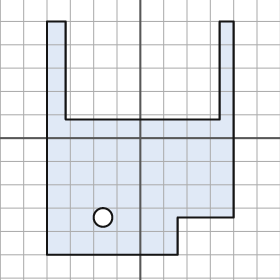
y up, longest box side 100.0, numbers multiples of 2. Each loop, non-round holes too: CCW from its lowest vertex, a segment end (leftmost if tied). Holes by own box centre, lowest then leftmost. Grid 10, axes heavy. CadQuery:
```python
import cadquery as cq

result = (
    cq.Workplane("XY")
    .moveTo(-40.0, -50.0)
    .lineTo(16.0, -50.0)
    .lineTo(16.0, -34.0)
    .lineTo(40.0, -34.0)
    .lineTo(40.0, 50.0)
    .lineTo(34.0, 50.0)
    .lineTo(34.0, 8.0)
    .lineTo(-32.0, 8.0)
    .lineTo(-32.0, 50.0)
    .lineTo(-40.0, 50.0)
    .close()
    .moveTo(-16.0, -34.0)
    .circle(4.0)
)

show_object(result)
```